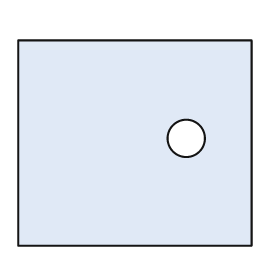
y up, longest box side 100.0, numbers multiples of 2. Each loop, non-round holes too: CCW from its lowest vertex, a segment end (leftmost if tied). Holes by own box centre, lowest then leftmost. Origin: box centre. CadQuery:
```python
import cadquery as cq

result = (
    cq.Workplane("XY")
    .moveTo(-50.0, -44.0)
    .lineTo(50.0, -44.0)
    .lineTo(50.0, 44.0)
    .lineTo(-50.0, 44.0)
    .close()
    .moveTo(22.0, 2.0)
    .circle(8.0)
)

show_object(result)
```